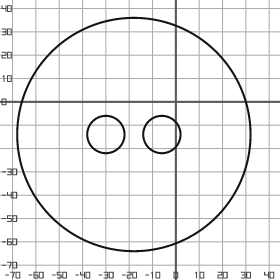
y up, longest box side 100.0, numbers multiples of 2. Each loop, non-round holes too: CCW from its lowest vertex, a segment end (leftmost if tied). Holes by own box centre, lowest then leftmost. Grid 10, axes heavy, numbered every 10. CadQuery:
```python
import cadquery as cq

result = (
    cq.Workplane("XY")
    .moveTo(-18.0, -14.0)
    .circle(50.0)
    .moveTo(-30.0, -14.0)
    .circle(8.0)
    .moveTo(-6.0, -14.0)
    .circle(8.0)
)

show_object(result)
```